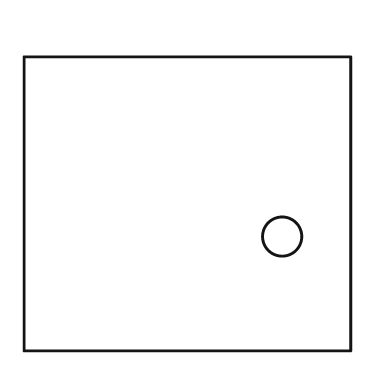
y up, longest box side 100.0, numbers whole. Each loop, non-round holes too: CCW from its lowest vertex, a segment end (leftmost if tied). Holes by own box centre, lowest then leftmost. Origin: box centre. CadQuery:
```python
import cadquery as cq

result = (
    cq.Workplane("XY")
    .moveTo(-50.0, -45.0)
    .lineTo(50.0, -45.0)
    .lineTo(50.0, 45.0)
    .lineTo(-50.0, 45.0)
    .close()
    .moveTo(29.0, -10.0)
    .circle(6.0)
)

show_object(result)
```